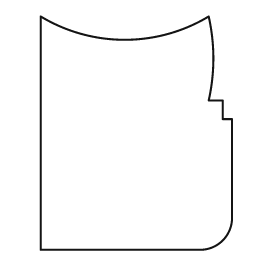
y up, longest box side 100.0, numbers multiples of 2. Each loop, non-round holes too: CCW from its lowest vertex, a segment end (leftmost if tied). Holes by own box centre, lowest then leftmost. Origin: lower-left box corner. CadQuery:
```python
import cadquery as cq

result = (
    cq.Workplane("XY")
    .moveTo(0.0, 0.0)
    .lineTo(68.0, 0.0)
    .threePointArc((78.0, 4.0), (82.0, 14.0))
    .lineTo(82.0, 56.0)
    .lineTo(78.0, 56.0)
    .lineTo(78.0, 64.0)
    .lineTo(72.0, 64.0)
    .threePointArc((74.0, 82.0), (72.0, 100.0))
    .threePointArc((36.0, 90.0), (0.0, 100.0))
    .close()
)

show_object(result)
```